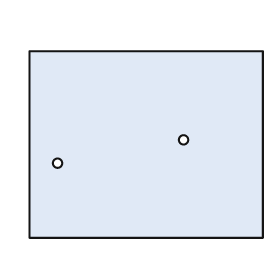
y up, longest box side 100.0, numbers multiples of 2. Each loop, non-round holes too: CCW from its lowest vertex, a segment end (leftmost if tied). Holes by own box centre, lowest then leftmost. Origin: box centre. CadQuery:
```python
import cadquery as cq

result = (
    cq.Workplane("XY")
    .moveTo(-50.0, -40.0)
    .lineTo(50.0, -40.0)
    .lineTo(50.0, 40.0)
    .lineTo(-50.0, 40.0)
    .close()
    .moveTo(-38.0, -8.0)
    .circle(2.0)
    .moveTo(16.0, 2.0)
    .circle(2.0)
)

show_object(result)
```